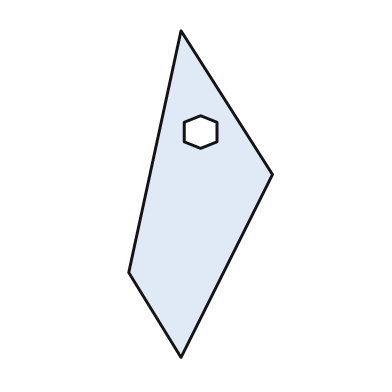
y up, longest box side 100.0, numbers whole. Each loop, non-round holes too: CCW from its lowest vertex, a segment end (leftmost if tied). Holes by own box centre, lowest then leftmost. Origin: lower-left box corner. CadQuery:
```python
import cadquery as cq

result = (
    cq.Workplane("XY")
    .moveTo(16.0, 0.0)
    .lineTo(44.0, 56.0)
    .lineTo(16.0, 100.0)
    .lineTo(0.0, 26.0)
    .close()
    .moveTo(22.0, 64.0)
    .lineTo(27.0, 66.0)
    .lineTo(27.0, 72.0)
    .lineTo(22.0, 74.0)
    .lineTo(17.0, 72.0)
    .lineTo(17.0, 66.0)
    .close()
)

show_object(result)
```